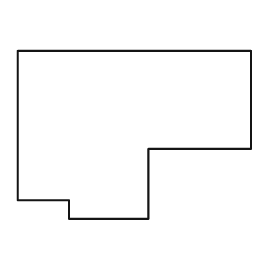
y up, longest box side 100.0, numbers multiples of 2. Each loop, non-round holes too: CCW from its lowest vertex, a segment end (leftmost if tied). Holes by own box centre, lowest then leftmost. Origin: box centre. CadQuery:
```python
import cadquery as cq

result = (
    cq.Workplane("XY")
    .moveTo(-28.0, -36.0)
    .lineTo(6.0, -36.0)
    .lineTo(6.0, -6.0)
    .lineTo(50.0, -6.0)
    .lineTo(50.0, 36.0)
    .lineTo(-50.0, 36.0)
    .lineTo(-50.0, -28.0)
    .lineTo(-28.0, -28.0)
    .close()
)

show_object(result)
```